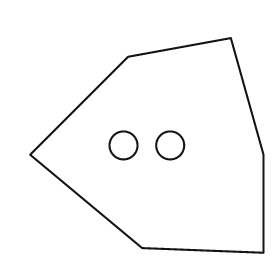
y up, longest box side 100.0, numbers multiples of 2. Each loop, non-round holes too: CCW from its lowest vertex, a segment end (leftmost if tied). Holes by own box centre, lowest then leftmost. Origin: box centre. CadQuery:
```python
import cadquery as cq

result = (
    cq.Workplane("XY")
    .moveTo(50.0, -46.0)
    .lineTo(50.0, -4.0)
    .lineTo(36.0, 46.0)
    .lineTo(-8.0, 38.0)
    .lineTo(-50.0, -4.0)
    .lineTo(-2.0, -44.0)
    .close()
    .moveTo(-10.0, 0.0)
    .circle(6.0)
    .moveTo(10.0, 0.0)
    .circle(6.0)
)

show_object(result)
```